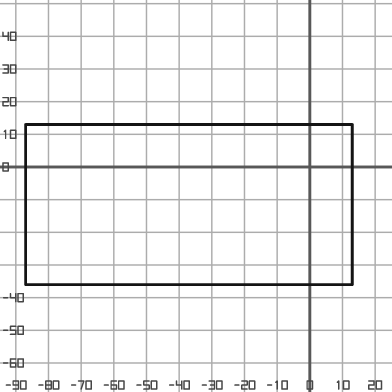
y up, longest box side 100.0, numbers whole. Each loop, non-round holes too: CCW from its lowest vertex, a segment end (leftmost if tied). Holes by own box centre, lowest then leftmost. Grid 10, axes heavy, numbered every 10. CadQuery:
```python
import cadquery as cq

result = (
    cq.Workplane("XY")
    .moveTo(-87.0, -36.0)
    .lineTo(13.0, -36.0)
    .lineTo(13.0, 13.0)
    .lineTo(-87.0, 13.0)
    .close()
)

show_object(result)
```